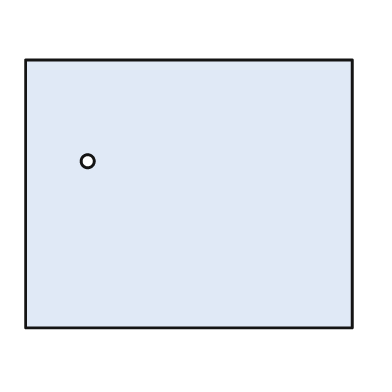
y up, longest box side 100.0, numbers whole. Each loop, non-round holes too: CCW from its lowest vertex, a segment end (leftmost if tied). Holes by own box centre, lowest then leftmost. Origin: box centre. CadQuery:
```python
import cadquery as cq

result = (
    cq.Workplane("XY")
    .moveTo(-50.0, -41.0)
    .lineTo(50.0, -41.0)
    .lineTo(50.0, 41.0)
    .lineTo(-50.0, 41.0)
    .close()
    .moveTo(-31.0, 10.0)
    .circle(2.0)
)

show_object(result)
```